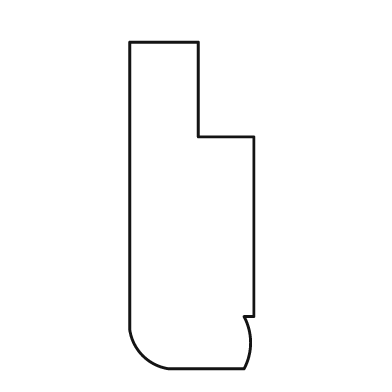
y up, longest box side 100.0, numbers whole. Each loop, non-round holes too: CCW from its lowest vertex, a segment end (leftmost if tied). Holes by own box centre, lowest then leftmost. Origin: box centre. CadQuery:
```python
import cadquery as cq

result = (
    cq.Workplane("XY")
    .moveTo(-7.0, -50.0)
    .lineTo(16.0, -50.0)
    .threePointArc((18.0, -42.0), (16.0, -34.0))
    .lineTo(19.0, -34.0)
    .lineTo(19.0, 21.0)
    .lineTo(2.0, 21.0)
    .lineTo(2.0, 50.0)
    .lineTo(-19.0, 50.0)
    .lineTo(-19.0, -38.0)
    .threePointArc((-15.0, -46.0), (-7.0, -50.0))
    .close()
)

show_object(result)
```